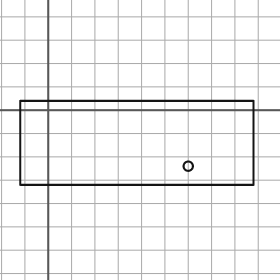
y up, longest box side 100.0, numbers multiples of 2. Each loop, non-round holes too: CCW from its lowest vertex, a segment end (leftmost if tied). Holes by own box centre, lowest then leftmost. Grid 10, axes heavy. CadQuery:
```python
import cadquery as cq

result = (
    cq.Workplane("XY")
    .moveTo(-12.0, -32.0)
    .lineTo(88.0, -32.0)
    .lineTo(88.0, 4.0)
    .lineTo(-12.0, 4.0)
    .close()
    .moveTo(60.0, -24.0)
    .circle(2.0)
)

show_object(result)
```